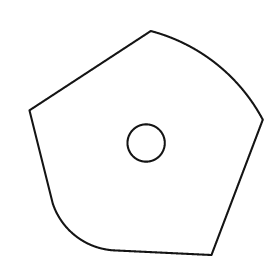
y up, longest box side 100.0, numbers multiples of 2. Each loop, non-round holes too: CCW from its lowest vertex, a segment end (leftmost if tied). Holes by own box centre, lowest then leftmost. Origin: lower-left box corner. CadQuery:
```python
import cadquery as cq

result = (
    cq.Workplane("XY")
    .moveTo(78.0, 0.0)
    .lineTo(100.0, 58.0)
    .threePointArc((80.0, 82.0), (52.0, 96.0))
    .lineTo(0.0, 62.0)
    .lineTo(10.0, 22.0)
    .threePointArc((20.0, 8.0), (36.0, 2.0))
    .close()
    .moveTo(50.0, 48.0)
    .circle(8.0)
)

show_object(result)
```